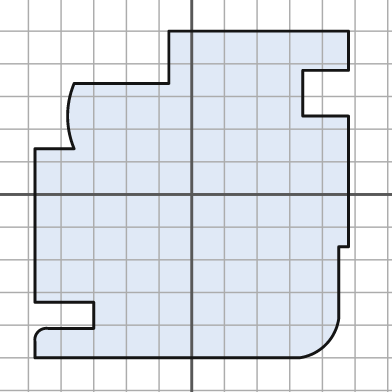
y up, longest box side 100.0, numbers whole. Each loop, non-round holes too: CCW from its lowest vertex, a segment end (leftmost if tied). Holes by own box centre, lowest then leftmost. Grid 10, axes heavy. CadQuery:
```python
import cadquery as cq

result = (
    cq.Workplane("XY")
    .moveTo(-48.0, -50.0)
    .lineTo(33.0, -50.0)
    .threePointArc((41.0, -46.0), (45.0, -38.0))
    .lineTo(45.0, -16.0)
    .lineTo(48.0, -16.0)
    .lineTo(48.0, 24.0)
    .lineTo(34.0, 24.0)
    .lineTo(34.0, 38.0)
    .lineTo(48.0, 38.0)
    .lineTo(48.0, 50.0)
    .lineTo(-7.0, 50.0)
    .lineTo(-7.0, 34.0)
    .lineTo(-36.0, 34.0)
    .threePointArc((-38.0, 24.0), (-36.0, 14.0))
    .lineTo(-48.0, 14.0)
    .lineTo(-48.0, -33.0)
    .lineTo(-30.0, -33.0)
    .lineTo(-30.0, -41.0)
    .lineTo(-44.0, -41.0)
    .threePointArc((-47.0, -42.0), (-48.0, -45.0))
    .close()
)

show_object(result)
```